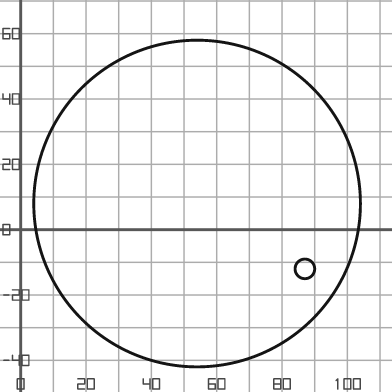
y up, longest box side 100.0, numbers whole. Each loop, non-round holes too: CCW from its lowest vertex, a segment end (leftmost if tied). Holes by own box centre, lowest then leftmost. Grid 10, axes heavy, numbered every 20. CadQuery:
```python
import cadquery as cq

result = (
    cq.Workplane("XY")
    .moveTo(54.0, 8.0)
    .circle(50.0)
    .moveTo(87.0, -12.0)
    .circle(3.0)
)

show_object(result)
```